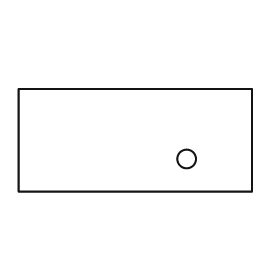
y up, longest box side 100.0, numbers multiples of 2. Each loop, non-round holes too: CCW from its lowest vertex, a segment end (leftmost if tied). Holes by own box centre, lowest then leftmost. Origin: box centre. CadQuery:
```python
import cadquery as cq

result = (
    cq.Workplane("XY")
    .moveTo(-50.0, -22.0)
    .lineTo(50.0, -22.0)
    .lineTo(50.0, 22.0)
    .lineTo(-50.0, 22.0)
    .close()
    .moveTo(22.0, -8.0)
    .circle(4.0)
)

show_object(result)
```